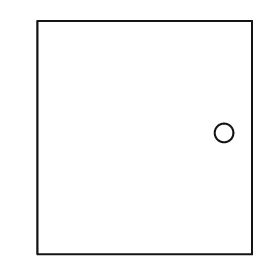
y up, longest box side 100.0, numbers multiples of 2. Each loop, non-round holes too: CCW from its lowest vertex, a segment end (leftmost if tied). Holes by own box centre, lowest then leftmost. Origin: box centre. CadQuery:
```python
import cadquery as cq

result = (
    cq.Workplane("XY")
    .moveTo(-46.0, -50.0)
    .lineTo(46.0, -50.0)
    .lineTo(46.0, 50.0)
    .lineTo(-46.0, 50.0)
    .close()
    .moveTo(34.0, 2.0)
    .circle(4.0)
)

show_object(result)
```